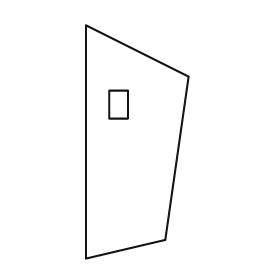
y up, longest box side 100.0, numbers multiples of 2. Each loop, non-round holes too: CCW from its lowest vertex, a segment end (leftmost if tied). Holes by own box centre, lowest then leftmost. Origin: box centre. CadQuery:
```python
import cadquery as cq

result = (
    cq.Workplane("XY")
    .moveTo(-22.0, -50.0)
    .lineTo(12.0, -42.0)
    .lineTo(22.0, 28.0)
    .lineTo(-22.0, 50.0)
    .close()
    .moveTo(-12.0, 10.0)
    .lineTo(-4.0, 10.0)
    .lineTo(-4.0, 22.0)
    .lineTo(-12.0, 22.0)
    .close()
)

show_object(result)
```